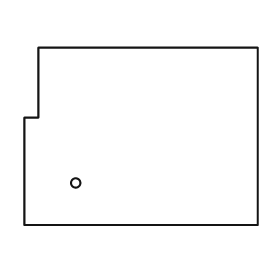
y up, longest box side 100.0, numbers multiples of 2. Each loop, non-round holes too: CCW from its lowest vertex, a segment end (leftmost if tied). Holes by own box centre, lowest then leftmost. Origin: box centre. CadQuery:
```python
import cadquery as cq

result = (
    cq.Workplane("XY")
    .moveTo(-50.0, -38.0)
    .lineTo(50.0, -38.0)
    .lineTo(50.0, 38.0)
    .lineTo(-44.0, 38.0)
    .lineTo(-44.0, 8.0)
    .lineTo(-50.0, 8.0)
    .close()
    .moveTo(-28.0, -20.0)
    .circle(2.0)
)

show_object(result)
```